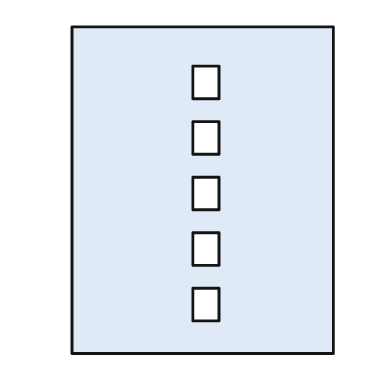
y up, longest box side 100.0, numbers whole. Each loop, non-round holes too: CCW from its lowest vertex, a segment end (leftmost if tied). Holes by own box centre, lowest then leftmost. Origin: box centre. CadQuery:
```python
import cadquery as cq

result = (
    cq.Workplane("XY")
    .moveTo(-40.0, -50.0)
    .lineTo(40.0, -50.0)
    .lineTo(40.0, 50.0)
    .lineTo(-40.0, 50.0)
    .close()
    .moveTo(-3.0, -40.0)
    .lineTo(5.0, -40.0)
    .lineTo(5.0, -30.0)
    .lineTo(-3.0, -30.0)
    .close()
    .moveTo(-3.0, -23.0)
    .lineTo(5.0, -23.0)
    .lineTo(5.0, -13.0)
    .lineTo(-3.0, -13.0)
    .close()
    .moveTo(-3.0, -6.0)
    .lineTo(5.0, -6.0)
    .lineTo(5.0, 4.0)
    .lineTo(-3.0, 4.0)
    .close()
    .moveTo(-3.0, 11.0)
    .lineTo(5.0, 11.0)
    .lineTo(5.0, 21.0)
    .lineTo(-3.0, 21.0)
    .close()
    .moveTo(-3.0, 28.0)
    .lineTo(5.0, 28.0)
    .lineTo(5.0, 38.0)
    .lineTo(-3.0, 38.0)
    .close()
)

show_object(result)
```